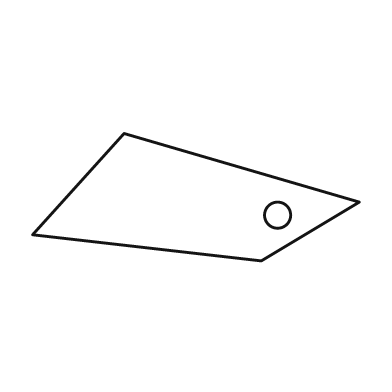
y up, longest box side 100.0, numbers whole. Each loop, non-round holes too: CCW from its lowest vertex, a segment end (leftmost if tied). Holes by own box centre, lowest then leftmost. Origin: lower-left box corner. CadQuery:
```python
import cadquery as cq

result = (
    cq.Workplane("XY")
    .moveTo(70.0, 0.0)
    .lineTo(100.0, 18.0)
    .lineTo(28.0, 39.0)
    .lineTo(0.0, 8.0)
    .close()
    .moveTo(75.0, 14.0)
    .circle(4.0)
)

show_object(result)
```